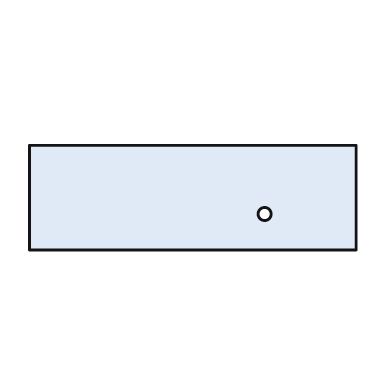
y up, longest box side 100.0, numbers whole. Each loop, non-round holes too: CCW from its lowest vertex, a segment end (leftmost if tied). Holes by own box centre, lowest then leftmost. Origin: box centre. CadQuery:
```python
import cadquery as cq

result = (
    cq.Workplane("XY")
    .moveTo(-50.0, -16.0)
    .lineTo(50.0, -16.0)
    .lineTo(50.0, 16.0)
    .lineTo(-50.0, 16.0)
    .close()
    .moveTo(22.0, -5.0)
    .circle(2.0)
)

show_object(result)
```